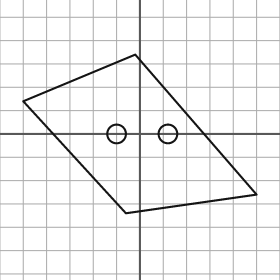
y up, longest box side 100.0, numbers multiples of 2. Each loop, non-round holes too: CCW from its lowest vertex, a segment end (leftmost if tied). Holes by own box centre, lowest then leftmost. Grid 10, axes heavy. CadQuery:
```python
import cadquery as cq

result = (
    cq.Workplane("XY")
    .moveTo(-6.0, -34.0)
    .lineTo(50.0, -26.0)
    .lineTo(-2.0, 34.0)
    .lineTo(-50.0, 14.0)
    .close()
    .moveTo(-10.0, 0.0)
    .circle(4.0)
    .moveTo(12.0, 0.0)
    .circle(4.0)
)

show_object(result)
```